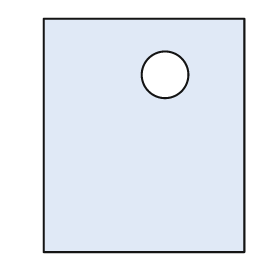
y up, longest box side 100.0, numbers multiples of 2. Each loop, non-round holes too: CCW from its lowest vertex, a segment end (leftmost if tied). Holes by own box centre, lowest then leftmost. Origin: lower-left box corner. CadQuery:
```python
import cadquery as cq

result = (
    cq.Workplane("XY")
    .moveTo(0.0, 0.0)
    .lineTo(86.0, 0.0)
    .lineTo(86.0, 100.0)
    .lineTo(0.0, 100.0)
    .close()
    .moveTo(52.0, 76.0)
    .circle(10.0)
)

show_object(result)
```